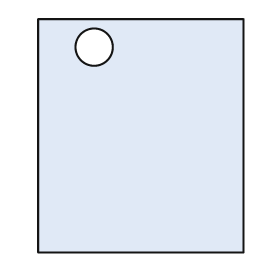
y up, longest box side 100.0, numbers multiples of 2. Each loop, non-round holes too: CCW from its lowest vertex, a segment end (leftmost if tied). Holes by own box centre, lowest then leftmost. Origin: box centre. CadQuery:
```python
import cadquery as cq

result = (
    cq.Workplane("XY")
    .moveTo(-44.0, -50.0)
    .lineTo(44.0, -50.0)
    .lineTo(44.0, 50.0)
    .lineTo(-44.0, 50.0)
    .close()
    .moveTo(-20.0, 38.0)
    .circle(8.0)
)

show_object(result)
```